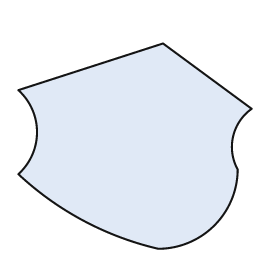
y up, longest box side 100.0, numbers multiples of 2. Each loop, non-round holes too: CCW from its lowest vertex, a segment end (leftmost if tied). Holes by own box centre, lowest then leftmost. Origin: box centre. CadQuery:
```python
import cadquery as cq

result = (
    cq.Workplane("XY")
    .moveTo(10.0, -44.0)
    .threePointArc((34.0, -34.0), (44.0, -10.0))
    .threePointArc((42.0, 4.0), (50.0, 16.0))
    .lineTo(12.0, 44.0)
    .lineTo(-50.0, 24.0)
    .threePointArc((-42.0, 6.0), (-50.0, -12.0))
    .threePointArc((-22.0, -32.0), (10.0, -44.0))
    .close()
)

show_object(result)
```